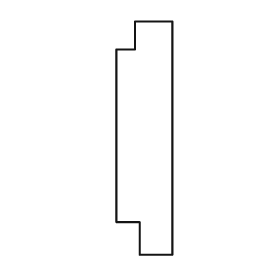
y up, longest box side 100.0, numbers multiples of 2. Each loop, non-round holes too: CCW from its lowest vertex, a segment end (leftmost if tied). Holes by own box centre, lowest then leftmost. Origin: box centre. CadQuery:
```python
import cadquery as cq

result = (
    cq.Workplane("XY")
    .moveTo(-2.0, -50.0)
    .lineTo(12.0, -50.0)
    .lineTo(12.0, 50.0)
    .lineTo(-4.0, 50.0)
    .lineTo(-4.0, 38.0)
    .lineTo(-12.0, 38.0)
    .lineTo(-12.0, -36.0)
    .lineTo(-2.0, -36.0)
    .close()
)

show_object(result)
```